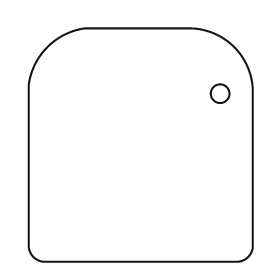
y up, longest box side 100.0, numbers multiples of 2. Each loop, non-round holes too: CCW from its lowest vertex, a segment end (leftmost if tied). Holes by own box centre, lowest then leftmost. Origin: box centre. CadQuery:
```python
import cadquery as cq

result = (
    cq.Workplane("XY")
    .moveTo(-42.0, -50.0)
    .lineTo(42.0, -50.0)
    .threePointArc((46.0, -48.0), (48.0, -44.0))
    .lineTo(48.0, 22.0)
    .threePointArc((40.0, 42.0), (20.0, 50.0))
    .lineTo(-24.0, 50.0)
    .threePointArc((-40.0, 42.0), (-48.0, 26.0))
    .lineTo(-48.0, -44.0)
    .threePointArc((-46.0, -48.0), (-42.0, -50.0))
    .close()
    .moveTo(34.0, 22.0)
    .circle(4.0)
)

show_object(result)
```